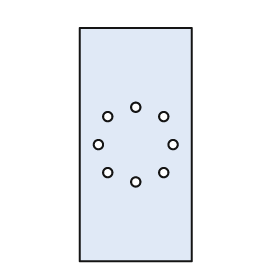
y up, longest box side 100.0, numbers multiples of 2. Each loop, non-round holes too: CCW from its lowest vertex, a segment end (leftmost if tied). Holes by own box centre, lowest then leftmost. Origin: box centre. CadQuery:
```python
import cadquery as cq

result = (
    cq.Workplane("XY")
    .moveTo(-24.0, -50.0)
    .lineTo(24.0, -50.0)
    .lineTo(24.0, 50.0)
    .lineTo(-24.0, 50.0)
    .close()
    .moveTo(0.0, -16.0)
    .circle(2.0)
    .moveTo(-12.0, -12.0)
    .circle(2.0)
    .moveTo(12.0, -12.0)
    .circle(2.0)
    .moveTo(-16.0, 0.0)
    .circle(2.0)
    .moveTo(16.0, 0.0)
    .circle(2.0)
    .moveTo(-12.0, 12.0)
    .circle(2.0)
    .moveTo(12.0, 12.0)
    .circle(2.0)
    .moveTo(0.0, 16.0)
    .circle(2.0)
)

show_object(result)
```